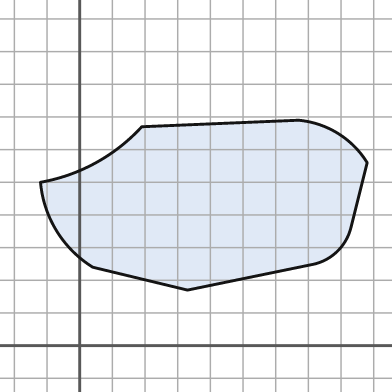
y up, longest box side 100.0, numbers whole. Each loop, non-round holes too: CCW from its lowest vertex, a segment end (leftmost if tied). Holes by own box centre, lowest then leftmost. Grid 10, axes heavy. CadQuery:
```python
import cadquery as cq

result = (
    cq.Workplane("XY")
    .moveTo(33.0, 17.0)
    .lineTo(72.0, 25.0)
    .threePointArc((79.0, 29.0), (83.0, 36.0))
    .lineTo(88.0, 56.0)
    .threePointArc((79.0, 65.0), (67.0, 69.0))
    .lineTo(19.0, 67.0)
    .threePointArc((5.0, 56.0), (-12.0, 50.0))
    .threePointArc((-7.0, 35.0), (4.0, 24.0))
    .close()
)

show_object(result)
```